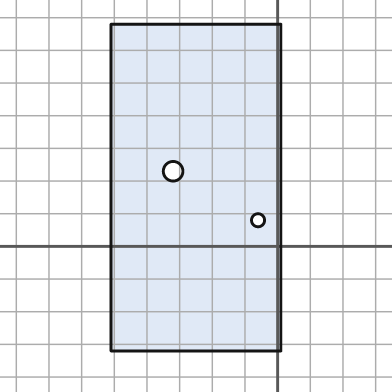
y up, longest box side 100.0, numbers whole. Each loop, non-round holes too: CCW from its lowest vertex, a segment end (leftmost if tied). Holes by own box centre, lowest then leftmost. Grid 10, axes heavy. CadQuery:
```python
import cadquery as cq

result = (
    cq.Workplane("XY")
    .moveTo(-51.0, -32.0)
    .lineTo(1.0, -32.0)
    .lineTo(1.0, 68.0)
    .lineTo(-51.0, 68.0)
    .close()
    .moveTo(-6.0, 8.0)
    .circle(2.0)
    .moveTo(-32.0, 23.0)
    .circle(3.0)
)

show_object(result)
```